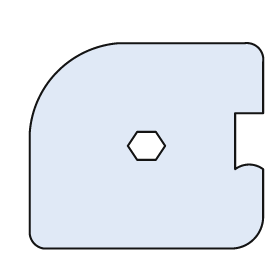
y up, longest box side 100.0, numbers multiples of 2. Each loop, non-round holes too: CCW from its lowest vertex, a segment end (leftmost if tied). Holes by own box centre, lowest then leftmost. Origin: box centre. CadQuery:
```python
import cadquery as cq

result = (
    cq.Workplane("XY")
    .moveTo(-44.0, -44.0)
    .lineTo(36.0, -44.0)
    .threePointArc((46.0, -40.0), (50.0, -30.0))
    .lineTo(50.0, -10.0)
    .threePointArc((44.0, -8.0), (38.0, -10.0))
    .lineTo(38.0, 14.0)
    .lineTo(50.0, 14.0)
    .lineTo(50.0, 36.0)
    .threePointArc((48.0, 42.0), (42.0, 44.0))
    .lineTo(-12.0, 44.0)
    .threePointArc((-38.0, 32.0), (-50.0, 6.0))
    .lineTo(-50.0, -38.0)
    .threePointArc((-48.0, -42.0), (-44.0, -44.0))
    .close()
    .moveTo(-4.0, -6.0)
    .lineTo(4.0, -6.0)
    .lineTo(8.0, 0.0)
    .lineTo(4.0, 6.0)
    .lineTo(-4.0, 6.0)
    .lineTo(-8.0, 0.0)
    .close()
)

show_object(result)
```